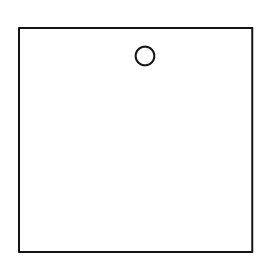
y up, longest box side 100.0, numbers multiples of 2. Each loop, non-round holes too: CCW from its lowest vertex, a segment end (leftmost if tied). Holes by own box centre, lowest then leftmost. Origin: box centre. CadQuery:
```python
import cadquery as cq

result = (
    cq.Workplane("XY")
    .moveTo(-50.0, -48.0)
    .lineTo(50.0, -48.0)
    .lineTo(50.0, 48.0)
    .lineTo(-50.0, 48.0)
    .close()
    .moveTo(4.0, 36.0)
    .circle(4.0)
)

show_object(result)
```